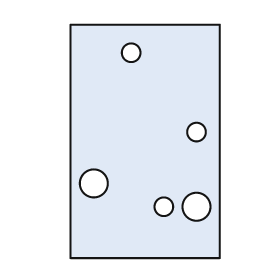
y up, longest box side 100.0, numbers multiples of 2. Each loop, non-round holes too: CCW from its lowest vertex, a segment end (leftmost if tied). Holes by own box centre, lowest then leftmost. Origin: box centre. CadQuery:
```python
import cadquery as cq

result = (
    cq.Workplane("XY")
    .moveTo(-32.0, -50.0)
    .lineTo(32.0, -50.0)
    .lineTo(32.0, 50.0)
    .lineTo(-32.0, 50.0)
    .close()
    .moveTo(8.0, -28.0)
    .circle(4.0)
    .moveTo(22.0, -28.0)
    .circle(6.0)
    .moveTo(-22.0, -18.0)
    .circle(6.0)
    .moveTo(22.0, 4.0)
    .circle(4.0)
    .moveTo(-6.0, 38.0)
    .circle(4.0)
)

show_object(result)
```